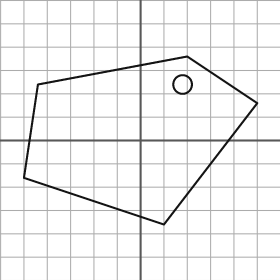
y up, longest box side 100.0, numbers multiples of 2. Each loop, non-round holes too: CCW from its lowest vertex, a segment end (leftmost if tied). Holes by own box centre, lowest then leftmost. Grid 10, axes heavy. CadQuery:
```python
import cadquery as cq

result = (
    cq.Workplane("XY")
    .moveTo(10.0, -36.0)
    .lineTo(50.0, 16.0)
    .lineTo(20.0, 36.0)
    .lineTo(-44.0, 24.0)
    .lineTo(-50.0, -16.0)
    .close()
    .moveTo(18.0, 24.0)
    .circle(4.0)
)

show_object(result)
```